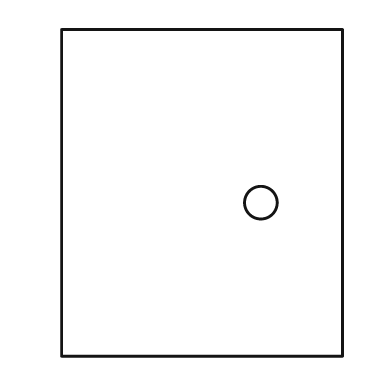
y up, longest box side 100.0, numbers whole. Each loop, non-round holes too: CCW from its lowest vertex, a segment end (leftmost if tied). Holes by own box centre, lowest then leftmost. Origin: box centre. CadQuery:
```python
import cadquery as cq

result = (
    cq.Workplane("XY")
    .moveTo(-43.0, -50.0)
    .lineTo(43.0, -50.0)
    .lineTo(43.0, 50.0)
    .lineTo(-43.0, 50.0)
    .close()
    .moveTo(18.0, -3.0)
    .circle(5.0)
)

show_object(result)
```